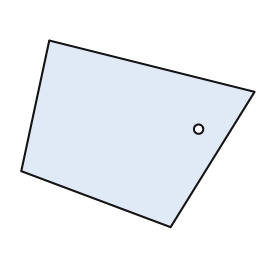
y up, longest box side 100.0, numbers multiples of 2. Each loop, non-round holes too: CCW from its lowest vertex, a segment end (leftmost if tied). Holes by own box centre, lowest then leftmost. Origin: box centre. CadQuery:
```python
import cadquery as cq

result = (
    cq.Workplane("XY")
    .moveTo(14.0, -40.0)
    .lineTo(50.0, 18.0)
    .lineTo(-38.0, 40.0)
    .lineTo(-50.0, -16.0)
    .close()
    .moveTo(26.0, 2.0)
    .circle(2.0)
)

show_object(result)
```